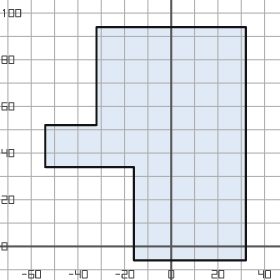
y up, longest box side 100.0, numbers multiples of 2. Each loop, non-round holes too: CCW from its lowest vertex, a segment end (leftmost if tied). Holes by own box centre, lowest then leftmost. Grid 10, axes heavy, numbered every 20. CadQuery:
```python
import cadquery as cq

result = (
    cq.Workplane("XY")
    .moveTo(-16.0, -6.0)
    .lineTo(32.0, -6.0)
    .lineTo(32.0, 94.0)
    .lineTo(-32.0, 94.0)
    .lineTo(-32.0, 52.0)
    .lineTo(-54.0, 52.0)
    .lineTo(-54.0, 34.0)
    .lineTo(-16.0, 34.0)
    .close()
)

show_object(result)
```